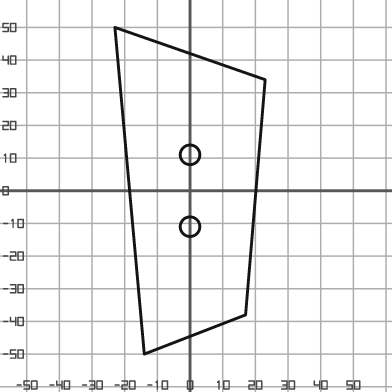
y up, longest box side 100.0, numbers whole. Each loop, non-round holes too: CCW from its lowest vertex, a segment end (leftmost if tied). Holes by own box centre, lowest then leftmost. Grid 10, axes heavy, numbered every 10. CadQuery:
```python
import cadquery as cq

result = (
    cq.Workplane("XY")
    .moveTo(-14.0, -50.0)
    .lineTo(17.0, -38.0)
    .lineTo(23.0, 34.0)
    .lineTo(-23.0, 50.0)
    .close()
    .moveTo(0.0, -11.0)
    .circle(3.0)
    .moveTo(0.0, 11.0)
    .circle(3.0)
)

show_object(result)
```